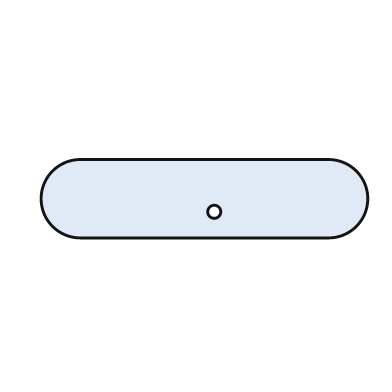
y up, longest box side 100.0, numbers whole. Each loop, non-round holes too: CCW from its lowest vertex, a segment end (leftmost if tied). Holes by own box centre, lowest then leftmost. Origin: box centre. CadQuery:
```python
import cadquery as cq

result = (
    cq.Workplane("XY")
    .moveTo(-38.0, -12.0)
    .lineTo(38.0, -12.0)
    .threePointArc((50.0, 0.0), (38.0, 12.0))
    .lineTo(-38.0, 12.0)
    .threePointArc((-50.0, 0.0), (-38.0, -12.0))
    .close()
    .moveTo(3.0, -4.0)
    .circle(2.0)
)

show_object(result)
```